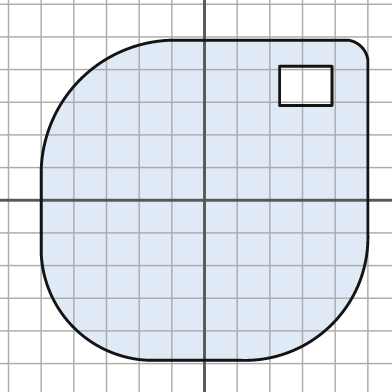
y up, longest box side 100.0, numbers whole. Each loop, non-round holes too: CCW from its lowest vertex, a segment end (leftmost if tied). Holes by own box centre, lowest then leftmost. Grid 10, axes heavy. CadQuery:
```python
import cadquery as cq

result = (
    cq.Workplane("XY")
    .moveTo(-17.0, -49.0)
    .lineTo(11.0, -49.0)
    .threePointArc((39.0, -38.0), (50.0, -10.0))
    .lineTo(50.0, 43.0)
    .threePointArc((48.0, 47.0), (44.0, 49.0))
    .lineTo(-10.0, 49.0)
    .threePointArc((-38.0, 37.0), (-50.0, 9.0))
    .lineTo(-50.0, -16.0)
    .threePointArc((-40.0, -39.0), (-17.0, -49.0))
    .close()
    .moveTo(23.0, 29.0)
    .lineTo(39.0, 29.0)
    .lineTo(39.0, 41.0)
    .lineTo(23.0, 41.0)
    .close()
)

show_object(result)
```